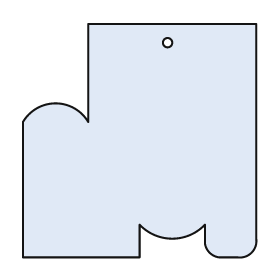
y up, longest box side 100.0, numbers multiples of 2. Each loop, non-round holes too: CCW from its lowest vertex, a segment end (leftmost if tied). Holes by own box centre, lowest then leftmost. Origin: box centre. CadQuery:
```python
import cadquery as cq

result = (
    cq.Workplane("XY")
    .moveTo(-50.0, -50.0)
    .lineTo(0.0, -50.0)
    .lineTo(0.0, -36.0)
    .threePointArc((14.0, -42.0), (28.0, -36.0))
    .lineTo(28.0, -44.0)
    .threePointArc((30.0, -48.0), (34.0, -50.0))
    .lineTo(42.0, -50.0)
    .threePointArc((48.0, -48.0), (50.0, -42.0))
    .lineTo(50.0, 50.0)
    .lineTo(-22.0, 50.0)
    .lineTo(-22.0, 8.0)
    .threePointArc((-36.0, 16.0), (-50.0, 8.0))
    .close()
    .moveTo(12.0, 42.0)
    .circle(2.0)
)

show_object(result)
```